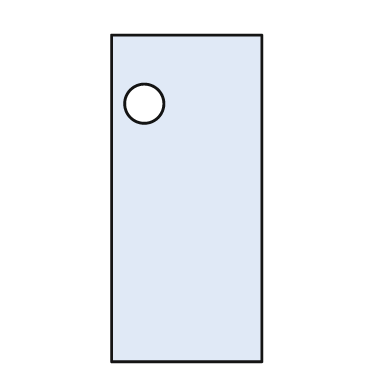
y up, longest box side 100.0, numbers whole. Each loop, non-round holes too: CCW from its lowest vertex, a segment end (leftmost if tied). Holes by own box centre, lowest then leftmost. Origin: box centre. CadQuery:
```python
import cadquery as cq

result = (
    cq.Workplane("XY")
    .moveTo(-23.0, -50.0)
    .lineTo(23.0, -50.0)
    .lineTo(23.0, 50.0)
    .lineTo(-23.0, 50.0)
    .close()
    .moveTo(-13.0, 29.0)
    .circle(6.0)
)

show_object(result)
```